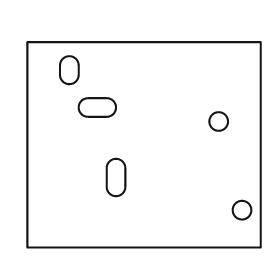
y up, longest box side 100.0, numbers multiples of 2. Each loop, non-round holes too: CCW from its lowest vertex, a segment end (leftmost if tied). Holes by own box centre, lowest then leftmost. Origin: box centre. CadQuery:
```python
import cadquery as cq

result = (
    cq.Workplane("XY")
    .moveTo(-50.0, -44.0)
    .lineTo(50.0, -44.0)
    .lineTo(50.0, 44.0)
    .lineTo(-50.0, 44.0)
    .close()
    .moveTo(42.0, -28.0)
    .circle(4.0)
    .moveTo(-16.0, -18.0)
    .threePointArc((-12.0, -22.0), (-8.0, -18.0))
    .lineTo(-8.0, -10.0)
    .threePointArc((-12.0, -6.0), (-16.0, -10.0))
    .close()
    .moveTo(32.0, 10.0)
    .circle(4.0)
    .moveTo(-24.0, 12.0)
    .lineTo(-16.0, 12.0)
    .threePointArc((-12.0, 16.0), (-16.0, 20.0))
    .lineTo(-24.0, 20.0)
    .threePointArc((-28.0, 16.0), (-24.0, 12.0))
    .close()
    .moveTo(-36.0, 30.0)
    .threePointArc((-32.0, 26.0), (-28.0, 30.0))
    .lineTo(-28.0, 34.0)
    .threePointArc((-32.0, 38.0), (-36.0, 34.0))
    .close()
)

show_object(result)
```